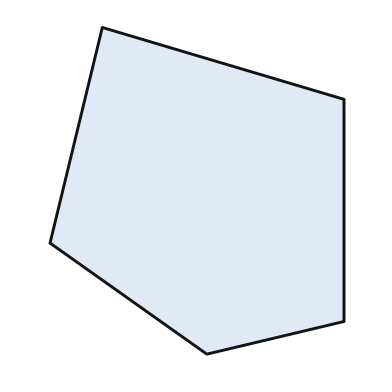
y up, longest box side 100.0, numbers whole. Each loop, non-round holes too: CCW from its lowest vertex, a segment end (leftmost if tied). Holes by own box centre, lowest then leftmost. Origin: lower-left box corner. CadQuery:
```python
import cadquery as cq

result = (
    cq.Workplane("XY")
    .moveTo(48.0, 0.0)
    .lineTo(90.0, 10.0)
    .lineTo(90.0, 78.0)
    .lineTo(16.0, 100.0)
    .lineTo(0.0, 34.0)
    .close()
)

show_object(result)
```